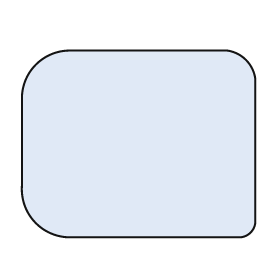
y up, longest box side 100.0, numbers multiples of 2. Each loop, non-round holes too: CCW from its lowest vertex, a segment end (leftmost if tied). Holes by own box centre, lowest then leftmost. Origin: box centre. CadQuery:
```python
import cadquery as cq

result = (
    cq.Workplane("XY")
    .moveTo(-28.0, -40.0)
    .lineTo(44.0, -40.0)
    .threePointArc((48.0, -38.0), (50.0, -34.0))
    .lineTo(50.0, 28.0)
    .threePointArc((46.0, 36.0), (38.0, 40.0))
    .lineTo(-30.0, 40.0)
    .threePointArc((-44.0, 34.0), (-50.0, 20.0))
    .lineTo(-50.0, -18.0)
    .threePointArc((-44.0, -34.0), (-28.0, -40.0))
    .close()
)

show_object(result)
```